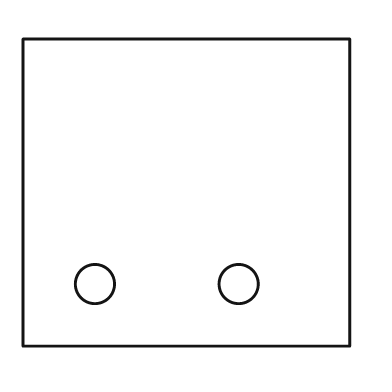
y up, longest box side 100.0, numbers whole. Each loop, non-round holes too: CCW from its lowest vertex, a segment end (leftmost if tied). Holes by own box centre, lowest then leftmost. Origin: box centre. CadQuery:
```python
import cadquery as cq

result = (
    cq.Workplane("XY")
    .moveTo(-50.0, -47.0)
    .lineTo(50.0, -47.0)
    .lineTo(50.0, 47.0)
    .lineTo(-50.0, 47.0)
    .close()
    .moveTo(-28.0, -28.0)
    .circle(6.0)
    .moveTo(16.0, -28.0)
    .circle(6.0)
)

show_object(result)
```